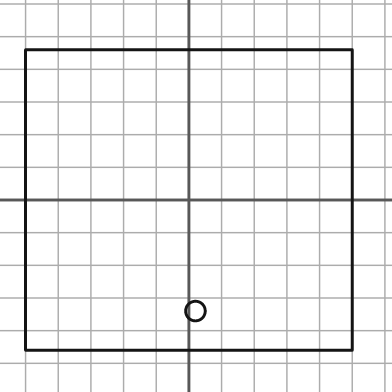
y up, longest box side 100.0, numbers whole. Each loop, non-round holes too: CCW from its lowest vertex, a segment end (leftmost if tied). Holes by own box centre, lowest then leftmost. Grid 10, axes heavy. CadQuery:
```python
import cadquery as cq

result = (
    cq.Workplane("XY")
    .moveTo(-50.0, -46.0)
    .lineTo(50.0, -46.0)
    .lineTo(50.0, 46.0)
    .lineTo(-50.0, 46.0)
    .close()
    .moveTo(2.0, -34.0)
    .circle(3.0)
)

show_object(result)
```